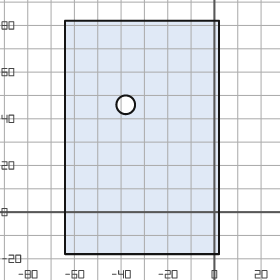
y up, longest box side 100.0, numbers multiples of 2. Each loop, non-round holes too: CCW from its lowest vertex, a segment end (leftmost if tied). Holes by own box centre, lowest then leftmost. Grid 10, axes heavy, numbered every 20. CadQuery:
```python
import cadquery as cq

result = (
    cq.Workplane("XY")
    .moveTo(-64.0, -18.0)
    .lineTo(2.0, -18.0)
    .lineTo(2.0, 82.0)
    .lineTo(-64.0, 82.0)
    .close()
    .moveTo(-38.0, 46.0)
    .circle(4.0)
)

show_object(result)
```